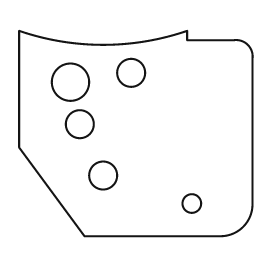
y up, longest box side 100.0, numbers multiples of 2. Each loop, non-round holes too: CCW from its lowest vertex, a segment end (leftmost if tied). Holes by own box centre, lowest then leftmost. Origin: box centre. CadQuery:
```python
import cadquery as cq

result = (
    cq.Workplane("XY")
    .moveTo(-22.0, -44.0)
    .lineTo(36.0, -44.0)
    .threePointArc((46.0, -40.0), (50.0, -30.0))
    .lineTo(50.0, 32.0)
    .threePointArc((48.0, 38.0), (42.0, 40.0))
    .lineTo(22.0, 40.0)
    .lineTo(22.0, 44.0)
    .threePointArc((-14.0, 38.0), (-50.0, 44.0))
    .lineTo(-50.0, -6.0)
    .close()
    .moveTo(24.0, -30.0)
    .circle(4.0)
    .moveTo(-14.0, -18.0)
    .circle(6.0)
    .moveTo(-24.0, 4.0)
    .circle(6.0)
    .moveTo(-28.0, 22.0)
    .circle(8.0)
    .moveTo(-2.0, 26.0)
    .circle(6.0)
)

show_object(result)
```